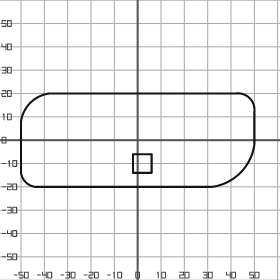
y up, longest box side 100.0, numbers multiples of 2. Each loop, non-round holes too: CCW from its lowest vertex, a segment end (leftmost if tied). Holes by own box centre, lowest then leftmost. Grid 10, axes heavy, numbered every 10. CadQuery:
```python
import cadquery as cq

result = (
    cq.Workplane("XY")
    .moveTo(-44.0, -20.0)
    .lineTo(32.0, -20.0)
    .threePointArc((44.0, -14.0), (50.0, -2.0))
    .lineTo(50.0, 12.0)
    .threePointArc((48.0, 18.0), (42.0, 20.0))
    .lineTo(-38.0, 20.0)
    .threePointArc((-46.0, 16.0), (-50.0, 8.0))
    .lineTo(-50.0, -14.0)
    .threePointArc((-48.0, -18.0), (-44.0, -20.0))
    .close()
    .moveTo(-2.0, -14.0)
    .lineTo(6.0, -14.0)
    .lineTo(6.0, -6.0)
    .lineTo(-2.0, -6.0)
    .close()
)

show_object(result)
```